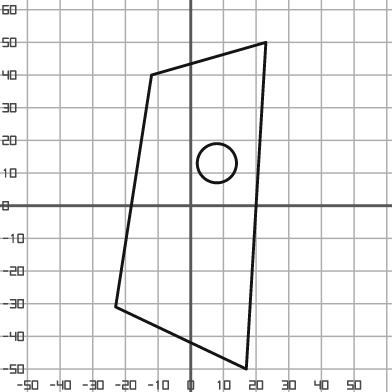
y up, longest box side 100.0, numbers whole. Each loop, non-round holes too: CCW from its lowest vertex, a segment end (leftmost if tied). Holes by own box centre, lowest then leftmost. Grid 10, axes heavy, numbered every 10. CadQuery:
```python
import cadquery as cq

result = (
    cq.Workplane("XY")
    .moveTo(17.0, -50.0)
    .lineTo(23.0, 50.0)
    .lineTo(-12.0, 40.0)
    .lineTo(-23.0, -31.0)
    .close()
    .moveTo(8.0, 13.0)
    .circle(6.0)
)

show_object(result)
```